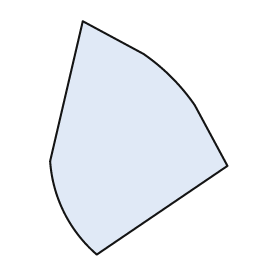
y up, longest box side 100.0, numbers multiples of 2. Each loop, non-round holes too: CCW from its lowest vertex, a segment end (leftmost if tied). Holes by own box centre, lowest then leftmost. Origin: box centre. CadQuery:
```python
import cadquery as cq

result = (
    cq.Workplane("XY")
    .moveTo(-18.0, -50.0)
    .lineTo(38.0, -12.0)
    .lineTo(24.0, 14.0)
    .threePointArc((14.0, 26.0), (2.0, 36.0))
    .lineTo(-24.0, 50.0)
    .lineTo(-38.0, -10.0)
    .threePointArc((-32.0, -32.0), (-18.0, -50.0))
    .close()
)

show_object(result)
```